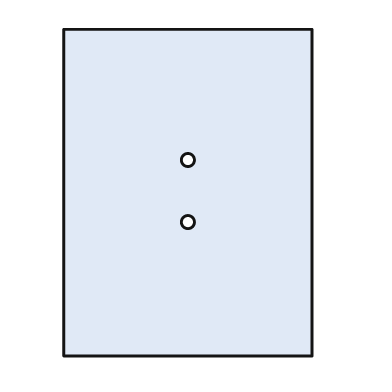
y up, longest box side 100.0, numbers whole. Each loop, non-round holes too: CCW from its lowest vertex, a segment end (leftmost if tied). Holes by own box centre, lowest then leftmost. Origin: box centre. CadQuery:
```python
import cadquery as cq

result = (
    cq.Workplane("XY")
    .moveTo(-38.0, -50.0)
    .lineTo(38.0, -50.0)
    .lineTo(38.0, 50.0)
    .lineTo(-38.0, 50.0)
    .close()
    .moveTo(0.0, -9.0)
    .circle(2.0)
    .moveTo(0.0, 10.0)
    .circle(2.0)
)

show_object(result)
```